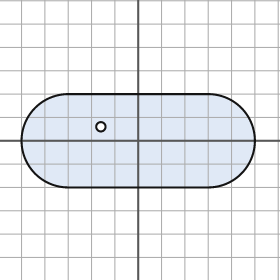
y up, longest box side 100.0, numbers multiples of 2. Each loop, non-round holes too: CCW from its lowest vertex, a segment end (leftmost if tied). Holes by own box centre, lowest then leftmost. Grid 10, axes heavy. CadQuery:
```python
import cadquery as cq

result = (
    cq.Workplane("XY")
    .moveTo(-30.0, -20.0)
    .lineTo(30.0, -20.0)
    .threePointArc((50.0, 0.0), (30.0, 20.0))
    .lineTo(-30.0, 20.0)
    .threePointArc((-50.0, 0.0), (-30.0, -20.0))
    .close()
    .moveTo(-16.0, 6.0)
    .circle(2.0)
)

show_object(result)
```